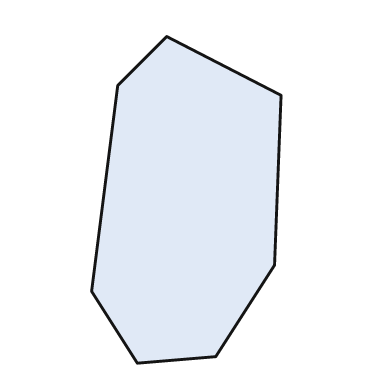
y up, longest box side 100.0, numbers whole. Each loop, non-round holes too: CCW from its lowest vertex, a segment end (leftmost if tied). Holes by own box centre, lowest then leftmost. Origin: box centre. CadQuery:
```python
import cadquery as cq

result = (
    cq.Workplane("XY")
    .moveTo(-15.0, -50.0)
    .lineTo(9.0, -48.0)
    .lineTo(27.0, -20.0)
    .lineTo(29.0, 32.0)
    .lineTo(-6.0, 50.0)
    .lineTo(-21.0, 35.0)
    .lineTo(-29.0, -28.0)
    .close()
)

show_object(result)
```